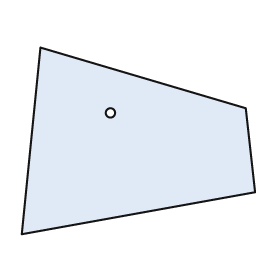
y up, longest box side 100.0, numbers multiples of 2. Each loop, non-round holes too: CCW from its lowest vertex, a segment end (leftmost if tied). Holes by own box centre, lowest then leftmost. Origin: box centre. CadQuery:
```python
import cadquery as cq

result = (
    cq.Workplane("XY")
    .moveTo(-50.0, -40.0)
    .lineTo(50.0, -22.0)
    .lineTo(46.0, 14.0)
    .lineTo(-42.0, 40.0)
    .close()
    .moveTo(-12.0, 12.0)
    .circle(2.0)
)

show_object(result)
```